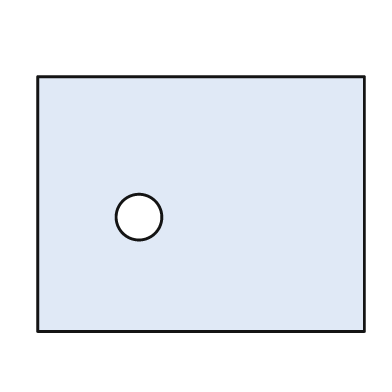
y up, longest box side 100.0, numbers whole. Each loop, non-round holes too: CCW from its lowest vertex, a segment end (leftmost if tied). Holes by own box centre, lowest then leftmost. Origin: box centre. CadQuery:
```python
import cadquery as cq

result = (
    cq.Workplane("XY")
    .moveTo(-50.0, -39.0)
    .lineTo(50.0, -39.0)
    .lineTo(50.0, 39.0)
    .lineTo(-50.0, 39.0)
    .close()
    .moveTo(-19.0, -4.0)
    .circle(7.0)
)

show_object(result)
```